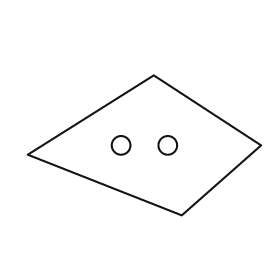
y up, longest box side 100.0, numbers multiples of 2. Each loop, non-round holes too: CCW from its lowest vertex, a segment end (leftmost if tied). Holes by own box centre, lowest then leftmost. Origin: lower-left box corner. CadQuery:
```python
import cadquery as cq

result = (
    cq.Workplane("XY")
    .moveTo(66.0, 0.0)
    .lineTo(100.0, 30.0)
    .lineTo(54.0, 60.0)
    .lineTo(0.0, 26.0)
    .close()
    .moveTo(40.0, 30.0)
    .circle(4.0)
    .moveTo(60.0, 30.0)
    .circle(4.0)
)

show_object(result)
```